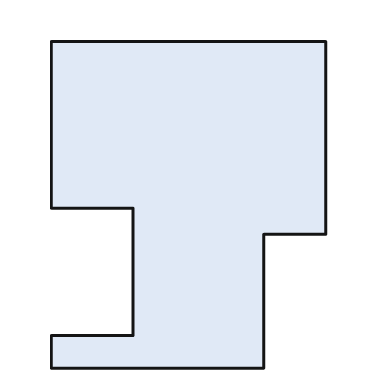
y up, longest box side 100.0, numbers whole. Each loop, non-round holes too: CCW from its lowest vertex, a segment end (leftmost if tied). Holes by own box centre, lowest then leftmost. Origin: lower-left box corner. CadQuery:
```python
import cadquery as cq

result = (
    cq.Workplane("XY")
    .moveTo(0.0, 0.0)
    .lineTo(65.0, 0.0)
    .lineTo(65.0, 41.0)
    .lineTo(84.0, 41.0)
    .lineTo(84.0, 100.0)
    .lineTo(0.0, 100.0)
    .lineTo(0.0, 49.0)
    .lineTo(25.0, 49.0)
    .lineTo(25.0, 10.0)
    .lineTo(0.0, 10.0)
    .close()
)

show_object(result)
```